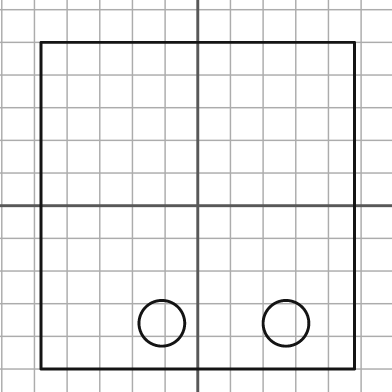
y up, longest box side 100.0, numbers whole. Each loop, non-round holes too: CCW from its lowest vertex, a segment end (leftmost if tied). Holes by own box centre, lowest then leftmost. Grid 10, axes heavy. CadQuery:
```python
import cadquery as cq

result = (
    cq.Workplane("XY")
    .moveTo(-48.0, -50.0)
    .lineTo(48.0, -50.0)
    .lineTo(48.0, 50.0)
    .lineTo(-48.0, 50.0)
    .close()
    .moveTo(-11.0, -36.0)
    .circle(7.0)
    .moveTo(27.0, -36.0)
    .circle(7.0)
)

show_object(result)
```